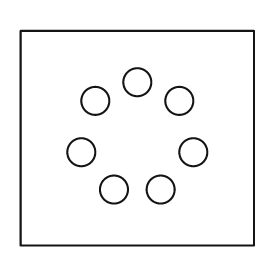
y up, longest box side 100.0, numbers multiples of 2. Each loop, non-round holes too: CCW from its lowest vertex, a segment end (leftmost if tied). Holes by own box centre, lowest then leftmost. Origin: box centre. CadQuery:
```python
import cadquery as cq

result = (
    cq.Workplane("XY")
    .moveTo(-50.0, -46.0)
    .lineTo(50.0, -46.0)
    .lineTo(50.0, 46.0)
    .lineTo(-50.0, 46.0)
    .close()
    .moveTo(-10.0, -22.0)
    .circle(6.0)
    .moveTo(10.0, -22.0)
    .circle(6.0)
    .moveTo(-24.0, -6.0)
    .circle(6.0)
    .moveTo(24.0, -6.0)
    .circle(6.0)
    .moveTo(-18.0, 16.0)
    .circle(6.0)
    .moveTo(18.0, 16.0)
    .circle(6.0)
    .moveTo(0.0, 24.0)
    .circle(6.0)
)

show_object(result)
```